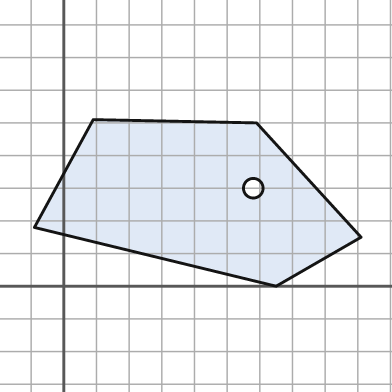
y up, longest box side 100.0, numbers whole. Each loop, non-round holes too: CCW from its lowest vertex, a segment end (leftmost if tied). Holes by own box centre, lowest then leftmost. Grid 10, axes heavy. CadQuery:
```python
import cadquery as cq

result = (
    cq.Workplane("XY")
    .moveTo(65.0, 0.0)
    .lineTo(91.0, 15.0)
    .lineTo(59.0, 50.0)
    .lineTo(9.0, 51.0)
    .lineTo(-9.0, 18.0)
    .close()
    .moveTo(58.0, 30.0)
    .circle(3.0)
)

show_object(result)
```